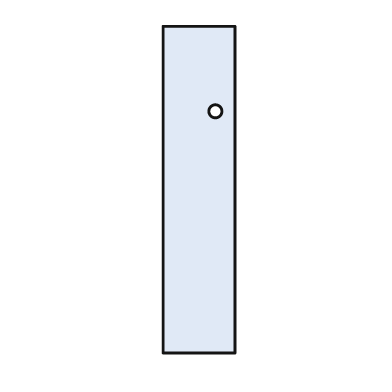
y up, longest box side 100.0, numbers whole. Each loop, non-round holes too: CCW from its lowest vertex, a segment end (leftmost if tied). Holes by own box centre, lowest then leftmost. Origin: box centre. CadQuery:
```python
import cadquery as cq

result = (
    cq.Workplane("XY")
    .moveTo(-11.0, -50.0)
    .lineTo(11.0, -50.0)
    .lineTo(11.0, 50.0)
    .lineTo(-11.0, 50.0)
    .close()
    .moveTo(5.0, 24.0)
    .circle(2.0)
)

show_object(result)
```